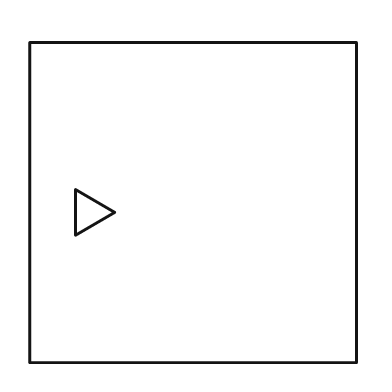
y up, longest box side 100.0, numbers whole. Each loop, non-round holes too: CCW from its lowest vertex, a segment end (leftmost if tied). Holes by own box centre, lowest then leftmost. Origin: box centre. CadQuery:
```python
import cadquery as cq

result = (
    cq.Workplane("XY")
    .moveTo(-50.0, -49.0)
    .lineTo(50.0, -49.0)
    .lineTo(50.0, 49.0)
    .lineTo(-50.0, 49.0)
    .close()
    .moveTo(-36.0, -10.0)
    .lineTo(-24.0, -3.0)
    .lineTo(-36.0, 4.0)
    .close()
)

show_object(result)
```